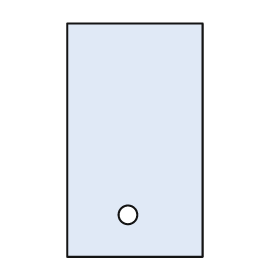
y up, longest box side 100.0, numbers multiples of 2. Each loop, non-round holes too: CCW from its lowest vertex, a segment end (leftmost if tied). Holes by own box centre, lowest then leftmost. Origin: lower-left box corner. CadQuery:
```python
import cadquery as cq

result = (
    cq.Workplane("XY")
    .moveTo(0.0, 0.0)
    .lineTo(58.0, 0.0)
    .lineTo(58.0, 100.0)
    .lineTo(0.0, 100.0)
    .close()
    .moveTo(26.0, 18.0)
    .circle(4.0)
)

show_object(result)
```